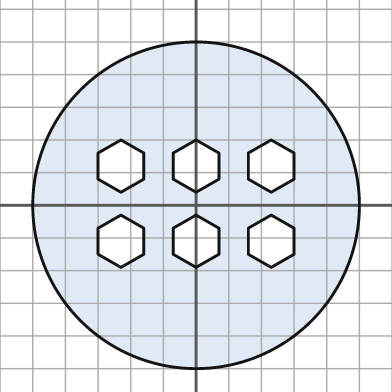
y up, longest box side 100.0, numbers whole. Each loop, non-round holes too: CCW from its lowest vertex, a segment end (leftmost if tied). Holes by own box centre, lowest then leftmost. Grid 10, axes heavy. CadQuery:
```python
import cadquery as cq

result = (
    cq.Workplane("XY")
    .moveTo(0.0, 0.0)
    .circle(50.0)
    .moveTo(-23.0, -19.0)
    .lineTo(-16.0, -15.0)
    .lineTo(-16.0, -7.0)
    .lineTo(-23.0, -3.0)
    .lineTo(-30.0, -7.0)
    .lineTo(-30.0, -15.0)
    .close()
    .moveTo(0.0, -19.0)
    .lineTo(7.0, -15.0)
    .lineTo(7.0, -7.0)
    .lineTo(0.0, -3.0)
    .lineTo(-7.0, -7.0)
    .lineTo(-7.0, -15.0)
    .close()
    .moveTo(23.0, -19.0)
    .lineTo(30.0, -15.0)
    .lineTo(30.0, -7.0)
    .lineTo(23.0, -3.0)
    .lineTo(16.0, -7.0)
    .lineTo(16.0, -15.0)
    .close()
    .moveTo(-23.0, 4.0)
    .lineTo(-16.0, 8.0)
    .lineTo(-16.0, 16.0)
    .lineTo(-23.0, 20.0)
    .lineTo(-30.0, 16.0)
    .lineTo(-30.0, 8.0)
    .close()
    .moveTo(0.0, 4.0)
    .lineTo(7.0, 8.0)
    .lineTo(7.0, 16.0)
    .lineTo(0.0, 20.0)
    .lineTo(-7.0, 16.0)
    .lineTo(-7.0, 8.0)
    .close()
    .moveTo(23.0, 4.0)
    .lineTo(30.0, 8.0)
    .lineTo(30.0, 16.0)
    .lineTo(23.0, 20.0)
    .lineTo(16.0, 16.0)
    .lineTo(16.0, 8.0)
    .close()
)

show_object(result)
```